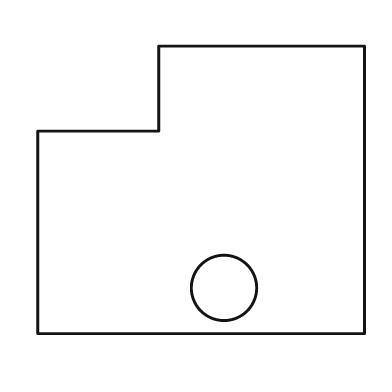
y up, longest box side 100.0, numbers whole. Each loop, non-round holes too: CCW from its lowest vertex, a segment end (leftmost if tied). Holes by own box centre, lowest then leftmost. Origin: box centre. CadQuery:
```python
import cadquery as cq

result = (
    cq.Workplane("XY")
    .moveTo(-50.0, -44.0)
    .lineTo(50.0, -44.0)
    .lineTo(50.0, 44.0)
    .lineTo(-13.0, 44.0)
    .lineTo(-13.0, 18.0)
    .lineTo(-50.0, 18.0)
    .close()
    .moveTo(7.0, -30.0)
    .circle(10.0)
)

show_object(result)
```